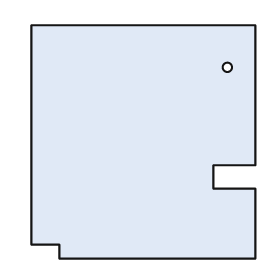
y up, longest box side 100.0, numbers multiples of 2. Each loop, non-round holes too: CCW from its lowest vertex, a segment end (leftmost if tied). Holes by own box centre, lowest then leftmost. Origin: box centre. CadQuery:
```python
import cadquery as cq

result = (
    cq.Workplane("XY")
    .moveTo(-36.0, -50.0)
    .lineTo(48.0, -50.0)
    .lineTo(48.0, -20.0)
    .lineTo(30.0, -20.0)
    .lineTo(30.0, -10.0)
    .lineTo(48.0, -10.0)
    .lineTo(48.0, 50.0)
    .lineTo(-48.0, 50.0)
    .lineTo(-48.0, -44.0)
    .lineTo(-36.0, -44.0)
    .close()
    .moveTo(36.0, 32.0)
    .circle(2.0)
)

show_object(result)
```